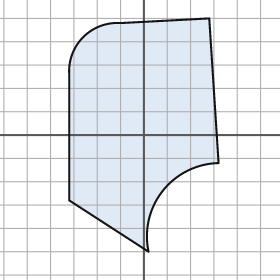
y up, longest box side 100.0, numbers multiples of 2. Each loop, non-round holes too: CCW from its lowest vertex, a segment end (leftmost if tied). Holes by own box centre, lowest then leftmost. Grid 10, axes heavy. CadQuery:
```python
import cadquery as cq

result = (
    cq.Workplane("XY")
    .moveTo(2.0, -50.0)
    .threePointArc((8.0, -24.0), (32.0, -12.0))
    .lineTo(28.0, 50.0)
    .lineTo(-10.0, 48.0)
    .threePointArc((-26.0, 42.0), (-32.0, 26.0))
    .lineTo(-32.0, -28.0)
    .close()
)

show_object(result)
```